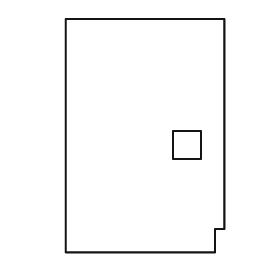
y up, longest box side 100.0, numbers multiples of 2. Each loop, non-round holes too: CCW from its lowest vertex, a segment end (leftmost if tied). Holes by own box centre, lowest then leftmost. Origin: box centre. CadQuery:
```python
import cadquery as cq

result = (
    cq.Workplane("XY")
    .moveTo(-34.0, -50.0)
    .lineTo(30.0, -50.0)
    .lineTo(30.0, -40.0)
    .lineTo(34.0, -40.0)
    .lineTo(34.0, 50.0)
    .lineTo(-34.0, 50.0)
    .close()
    .moveTo(12.0, -10.0)
    .lineTo(24.0, -10.0)
    .lineTo(24.0, 2.0)
    .lineTo(12.0, 2.0)
    .close()
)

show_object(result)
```